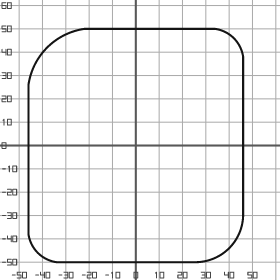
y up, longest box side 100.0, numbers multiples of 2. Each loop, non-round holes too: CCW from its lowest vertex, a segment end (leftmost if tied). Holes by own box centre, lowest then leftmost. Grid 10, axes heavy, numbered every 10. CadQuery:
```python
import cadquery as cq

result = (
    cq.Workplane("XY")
    .moveTo(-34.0, -50.0)
    .lineTo(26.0, -50.0)
    .threePointArc((40.0, -44.0), (46.0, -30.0))
    .lineTo(46.0, 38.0)
    .threePointArc((42.0, 46.0), (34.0, 50.0))
    .lineTo(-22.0, 50.0)
    .threePointArc((-38.0, 42.0), (-46.0, 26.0))
    .lineTo(-46.0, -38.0)
    .threePointArc((-42.0, -46.0), (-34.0, -50.0))
    .close()
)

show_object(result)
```